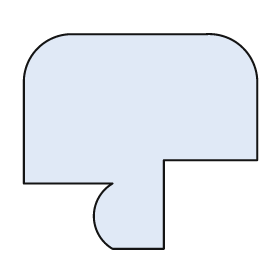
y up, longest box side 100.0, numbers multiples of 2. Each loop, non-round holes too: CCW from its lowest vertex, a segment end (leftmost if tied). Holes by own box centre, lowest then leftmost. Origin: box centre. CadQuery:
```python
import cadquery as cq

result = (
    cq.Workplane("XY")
    .moveTo(-12.0, -46.0)
    .lineTo(10.0, -46.0)
    .lineTo(10.0, -8.0)
    .lineTo(50.0, -8.0)
    .lineTo(50.0, 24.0)
    .threePointArc((44.0, 40.0), (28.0, 46.0))
    .lineTo(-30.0, 46.0)
    .threePointArc((-44.0, 40.0), (-50.0, 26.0))
    .lineTo(-50.0, -18.0)
    .lineTo(-12.0, -18.0)
    .threePointArc((-20.0, -32.0), (-12.0, -46.0))
    .close()
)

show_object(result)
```